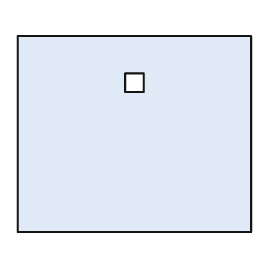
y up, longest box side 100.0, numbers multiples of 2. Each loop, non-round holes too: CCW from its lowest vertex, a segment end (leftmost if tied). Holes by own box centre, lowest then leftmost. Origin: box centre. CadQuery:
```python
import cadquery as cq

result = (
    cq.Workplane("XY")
    .moveTo(-50.0, -42.0)
    .lineTo(50.0, -42.0)
    .lineTo(50.0, 42.0)
    .lineTo(-50.0, 42.0)
    .close()
    .moveTo(-4.0, 18.0)
    .lineTo(4.0, 18.0)
    .lineTo(4.0, 26.0)
    .lineTo(-4.0, 26.0)
    .close()
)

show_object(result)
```